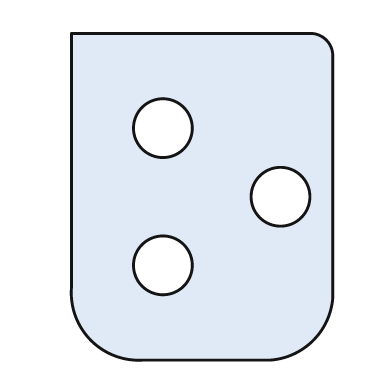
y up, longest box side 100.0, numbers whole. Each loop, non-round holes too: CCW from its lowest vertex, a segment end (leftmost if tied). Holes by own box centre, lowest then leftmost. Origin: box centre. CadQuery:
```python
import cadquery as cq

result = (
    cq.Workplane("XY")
    .moveTo(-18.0, -50.0)
    .lineTo(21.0, -50.0)
    .threePointArc((34.0, -44.0), (40.0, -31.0))
    .lineTo(40.0, 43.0)
    .threePointArc((38.0, 48.0), (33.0, 50.0))
    .lineTo(-40.0, 50.0)
    .lineTo(-40.0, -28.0)
    .threePointArc((-34.0, -44.0), (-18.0, -50.0))
    .close()
    .moveTo(-12.0, -21.0)
    .circle(9.0)
    .moveTo(24.0, 0.0)
    .circle(9.0)
    .moveTo(-12.0, 21.0)
    .circle(9.0)
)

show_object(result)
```